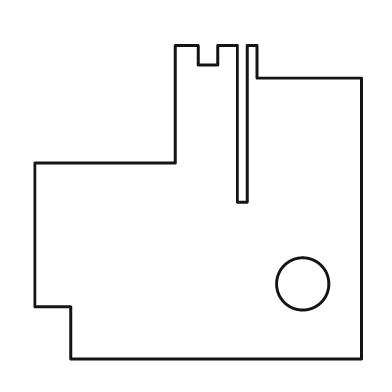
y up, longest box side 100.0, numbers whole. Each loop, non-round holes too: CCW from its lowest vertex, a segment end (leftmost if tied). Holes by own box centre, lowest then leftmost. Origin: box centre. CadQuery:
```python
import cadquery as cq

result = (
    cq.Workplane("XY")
    .moveTo(-39.0, -48.0)
    .lineTo(50.0, -48.0)
    .lineTo(50.0, 38.0)
    .lineTo(18.0, 38.0)
    .lineTo(18.0, 48.0)
    .lineTo(15.0, 48.0)
    .lineTo(15.0, 0.0)
    .lineTo(12.0, 0.0)
    .lineTo(12.0, 48.0)
    .lineTo(6.0, 48.0)
    .lineTo(6.0, 42.0)
    .lineTo(0.0, 42.0)
    .lineTo(0.0, 48.0)
    .lineTo(-7.0, 48.0)
    .lineTo(-7.0, 12.0)
    .lineTo(-50.0, 12.0)
    .lineTo(-50.0, -32.0)
    .lineTo(-39.0, -32.0)
    .close()
    .moveTo(32.0, -25.0)
    .circle(8.0)
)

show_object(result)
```